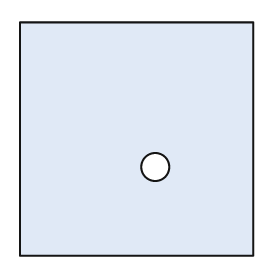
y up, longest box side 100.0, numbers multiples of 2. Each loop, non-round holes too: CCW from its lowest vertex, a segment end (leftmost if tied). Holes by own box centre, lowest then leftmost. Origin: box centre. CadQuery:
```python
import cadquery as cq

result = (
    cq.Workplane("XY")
    .moveTo(-50.0, -50.0)
    .lineTo(50.0, -50.0)
    .lineTo(50.0, 50.0)
    .lineTo(-50.0, 50.0)
    .close()
    .moveTo(8.0, -12.0)
    .circle(6.0)
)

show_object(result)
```